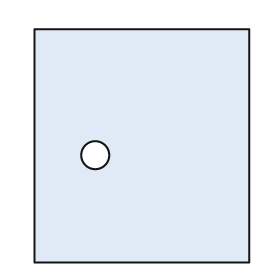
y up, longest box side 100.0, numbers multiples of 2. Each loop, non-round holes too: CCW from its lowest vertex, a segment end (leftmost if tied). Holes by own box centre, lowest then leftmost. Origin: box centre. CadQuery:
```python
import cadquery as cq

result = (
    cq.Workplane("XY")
    .moveTo(-46.0, -50.0)
    .lineTo(46.0, -50.0)
    .lineTo(46.0, 50.0)
    .lineTo(-46.0, 50.0)
    .close()
    .moveTo(-20.0, -4.0)
    .circle(6.0)
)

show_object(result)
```